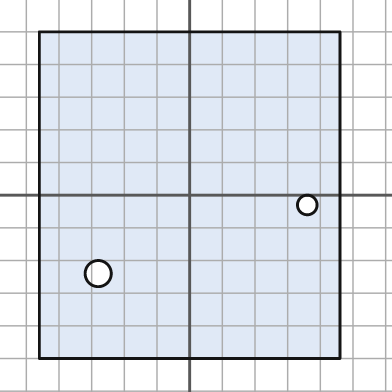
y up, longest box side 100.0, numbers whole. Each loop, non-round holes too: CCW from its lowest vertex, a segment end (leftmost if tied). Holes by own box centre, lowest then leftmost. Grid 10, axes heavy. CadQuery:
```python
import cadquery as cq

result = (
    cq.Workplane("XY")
    .moveTo(-46.0, -50.0)
    .lineTo(46.0, -50.0)
    .lineTo(46.0, 50.0)
    .lineTo(-46.0, 50.0)
    .close()
    .moveTo(-28.0, -24.0)
    .circle(4.0)
    .moveTo(36.0, -3.0)
    .circle(3.0)
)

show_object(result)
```